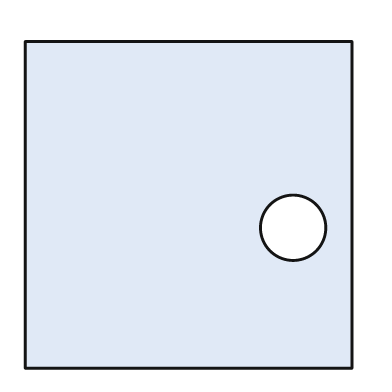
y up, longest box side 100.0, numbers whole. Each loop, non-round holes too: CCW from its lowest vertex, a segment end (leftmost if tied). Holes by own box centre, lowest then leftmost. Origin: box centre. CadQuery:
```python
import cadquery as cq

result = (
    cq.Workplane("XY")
    .moveTo(-50.0, -50.0)
    .lineTo(50.0, -50.0)
    .lineTo(50.0, 50.0)
    .lineTo(-50.0, 50.0)
    .close()
    .moveTo(32.0, -7.0)
    .circle(10.0)
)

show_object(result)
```